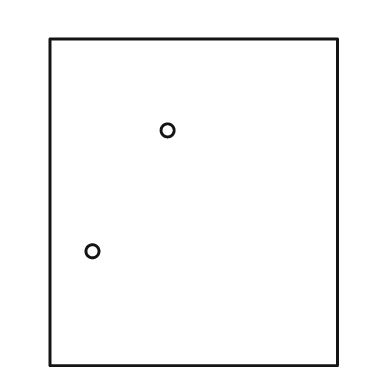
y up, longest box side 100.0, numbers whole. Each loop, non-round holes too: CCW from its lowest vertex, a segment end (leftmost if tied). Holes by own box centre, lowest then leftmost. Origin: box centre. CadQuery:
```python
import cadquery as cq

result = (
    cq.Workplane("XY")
    .moveTo(-44.0, -50.0)
    .lineTo(44.0, -50.0)
    .lineTo(44.0, 50.0)
    .lineTo(-44.0, 50.0)
    .close()
    .moveTo(-31.0, -15.0)
    .circle(2.0)
    .moveTo(-8.0, 22.0)
    .circle(2.0)
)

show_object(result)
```